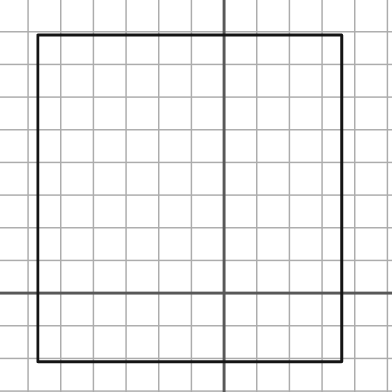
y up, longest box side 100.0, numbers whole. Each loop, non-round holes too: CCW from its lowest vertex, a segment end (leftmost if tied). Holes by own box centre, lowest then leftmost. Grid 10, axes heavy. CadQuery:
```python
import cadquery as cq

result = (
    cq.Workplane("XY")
    .moveTo(-57.0, -21.0)
    .lineTo(36.0, -21.0)
    .lineTo(36.0, 79.0)
    .lineTo(-57.0, 79.0)
    .close()
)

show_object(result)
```